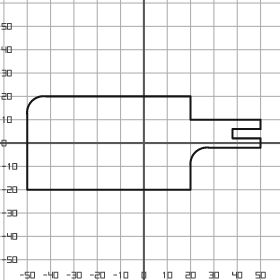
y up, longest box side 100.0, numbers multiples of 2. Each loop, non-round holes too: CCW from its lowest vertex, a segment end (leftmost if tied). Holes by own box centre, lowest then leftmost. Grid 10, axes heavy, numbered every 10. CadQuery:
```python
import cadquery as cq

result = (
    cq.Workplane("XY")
    .moveTo(-50.0, -20.0)
    .lineTo(20.0, -20.0)
    .lineTo(20.0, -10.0)
    .threePointArc((22.0, -4.0), (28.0, -2.0))
    .lineTo(50.0, -2.0)
    .lineTo(50.0, 2.0)
    .lineTo(38.0, 2.0)
    .lineTo(38.0, 6.0)
    .lineTo(50.0, 6.0)
    .lineTo(50.0, 10.0)
    .lineTo(20.0, 10.0)
    .lineTo(20.0, 20.0)
    .lineTo(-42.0, 20.0)
    .threePointArc((-48.0, 18.0), (-50.0, 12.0))
    .close()
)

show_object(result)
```